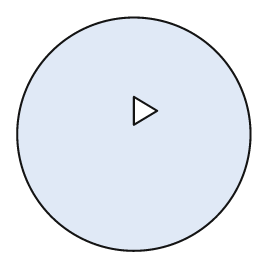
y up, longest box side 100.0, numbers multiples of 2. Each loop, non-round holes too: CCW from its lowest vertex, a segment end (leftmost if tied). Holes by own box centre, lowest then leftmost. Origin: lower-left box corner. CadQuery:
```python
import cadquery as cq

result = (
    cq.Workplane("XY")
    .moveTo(50.0, 50.0)
    .circle(50.0)
    .moveTo(50.0, 54.0)
    .lineTo(60.0, 60.0)
    .lineTo(50.0, 66.0)
    .close()
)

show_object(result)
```